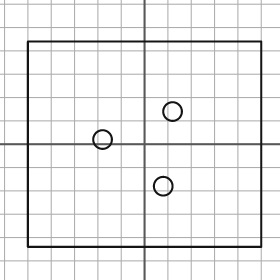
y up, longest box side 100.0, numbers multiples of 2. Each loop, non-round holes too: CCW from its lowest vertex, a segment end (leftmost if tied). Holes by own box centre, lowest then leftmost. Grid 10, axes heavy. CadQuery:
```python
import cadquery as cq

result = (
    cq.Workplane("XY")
    .moveTo(-50.0, -44.0)
    .lineTo(50.0, -44.0)
    .lineTo(50.0, 44.0)
    .lineTo(-50.0, 44.0)
    .close()
    .moveTo(8.0, -18.0)
    .circle(4.0)
    .moveTo(-18.0, 2.0)
    .circle(4.0)
    .moveTo(12.0, 14.0)
    .circle(4.0)
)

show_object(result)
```